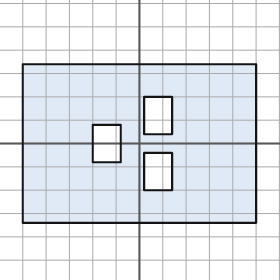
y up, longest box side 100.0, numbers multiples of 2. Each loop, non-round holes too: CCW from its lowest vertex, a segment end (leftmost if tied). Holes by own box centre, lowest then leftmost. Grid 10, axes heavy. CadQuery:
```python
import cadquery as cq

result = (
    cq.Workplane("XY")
    .moveTo(-50.0, -34.0)
    .lineTo(50.0, -34.0)
    .lineTo(50.0, 34.0)
    .lineTo(-50.0, 34.0)
    .close()
    .moveTo(2.0, -20.0)
    .lineTo(14.0, -20.0)
    .lineTo(14.0, -4.0)
    .lineTo(2.0, -4.0)
    .close()
    .moveTo(-20.0, -8.0)
    .lineTo(-8.0, -8.0)
    .lineTo(-8.0, 8.0)
    .lineTo(-20.0, 8.0)
    .close()
    .moveTo(2.0, 4.0)
    .lineTo(14.0, 4.0)
    .lineTo(14.0, 20.0)
    .lineTo(2.0, 20.0)
    .close()
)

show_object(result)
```